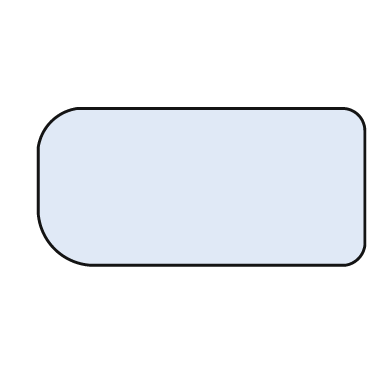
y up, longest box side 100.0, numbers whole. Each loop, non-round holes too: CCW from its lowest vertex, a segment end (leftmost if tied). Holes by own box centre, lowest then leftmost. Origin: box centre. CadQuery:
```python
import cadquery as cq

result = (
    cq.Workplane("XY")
    .moveTo(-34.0, -24.0)
    .lineTo(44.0, -24.0)
    .threePointArc((48.0, -22.0), (50.0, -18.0))
    .lineTo(50.0, 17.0)
    .threePointArc((48.0, 22.0), (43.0, 24.0))
    .lineTo(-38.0, 24.0)
    .threePointArc((-46.0, 20.0), (-50.0, 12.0))
    .lineTo(-50.0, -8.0)
    .threePointArc((-45.0, -19.0), (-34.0, -24.0))
    .close()
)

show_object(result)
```